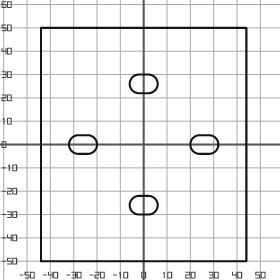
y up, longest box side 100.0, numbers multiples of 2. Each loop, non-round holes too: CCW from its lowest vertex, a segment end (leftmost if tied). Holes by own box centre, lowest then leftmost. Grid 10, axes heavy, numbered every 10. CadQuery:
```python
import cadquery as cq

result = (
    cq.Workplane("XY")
    .moveTo(-44.0, -50.0)
    .lineTo(44.0, -50.0)
    .lineTo(44.0, 50.0)
    .lineTo(-44.0, 50.0)
    .close()
    .moveTo(-2.0, -30.0)
    .lineTo(2.0, -30.0)
    .threePointArc((6.0, -26.0), (2.0, -22.0))
    .lineTo(-2.0, -22.0)
    .threePointArc((-6.0, -26.0), (-2.0, -30.0))
    .close()
    .moveTo(-28.0, -4.0)
    .lineTo(-24.0, -4.0)
    .threePointArc((-20.0, 0.0), (-24.0, 4.0))
    .lineTo(-28.0, 4.0)
    .threePointArc((-32.0, 0.0), (-28.0, -4.0))
    .close()
    .moveTo(24.0, -4.0)
    .lineTo(28.0, -4.0)
    .threePointArc((32.0, 0.0), (28.0, 4.0))
    .lineTo(24.0, 4.0)
    .threePointArc((20.0, 0.0), (24.0, -4.0))
    .close()
    .moveTo(-2.0, 22.0)
    .lineTo(2.0, 22.0)
    .threePointArc((6.0, 26.0), (2.0, 30.0))
    .lineTo(-2.0, 30.0)
    .threePointArc((-6.0, 26.0), (-2.0, 22.0))
    .close()
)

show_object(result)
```